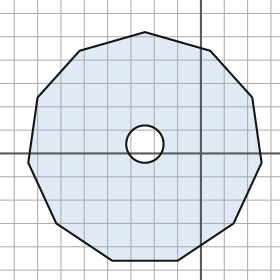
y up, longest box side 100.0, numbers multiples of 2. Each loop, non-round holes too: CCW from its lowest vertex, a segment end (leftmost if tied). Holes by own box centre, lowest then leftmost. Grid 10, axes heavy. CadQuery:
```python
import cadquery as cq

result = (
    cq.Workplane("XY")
    .moveTo(-38.0, -46.0)
    .lineTo(-10.0, -46.0)
    .lineTo(14.0, -30.0)
    .lineTo(26.0, -4.0)
    .lineTo(22.0, 24.0)
    .lineTo(4.0, 44.0)
    .lineTo(-24.0, 52.0)
    .lineTo(-52.0, 44.0)
    .lineTo(-70.0, 24.0)
    .lineTo(-74.0, -4.0)
    .lineTo(-62.0, -30.0)
    .close()
    .moveTo(-24.0, 4.0)
    .circle(8.0)
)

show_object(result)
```